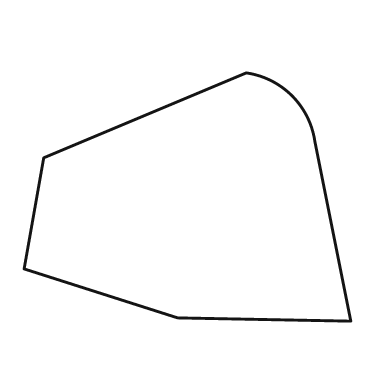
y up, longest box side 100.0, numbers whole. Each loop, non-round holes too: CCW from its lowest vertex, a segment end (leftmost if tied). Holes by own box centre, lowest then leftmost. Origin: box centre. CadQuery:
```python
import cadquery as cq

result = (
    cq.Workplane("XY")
    .moveTo(50.0, -38.0)
    .lineTo(39.0, 17.0)
    .threePointArc((32.0, 31.0), (18.0, 38.0))
    .lineTo(-44.0, 12.0)
    .lineTo(-50.0, -22.0)
    .lineTo(-3.0, -37.0)
    .close()
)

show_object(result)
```